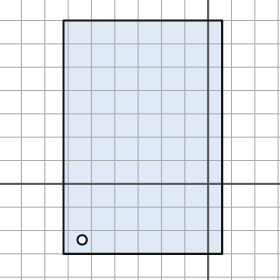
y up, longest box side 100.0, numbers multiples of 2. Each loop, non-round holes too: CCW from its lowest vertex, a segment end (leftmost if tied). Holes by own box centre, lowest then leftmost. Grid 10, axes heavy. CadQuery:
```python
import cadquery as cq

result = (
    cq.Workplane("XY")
    .moveTo(-62.0, -30.0)
    .lineTo(6.0, -30.0)
    .lineTo(6.0, 70.0)
    .lineTo(-62.0, 70.0)
    .close()
    .moveTo(-54.0, -24.0)
    .circle(2.0)
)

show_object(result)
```